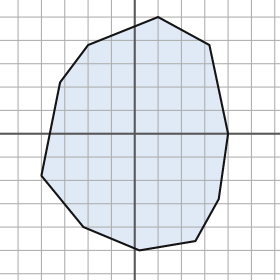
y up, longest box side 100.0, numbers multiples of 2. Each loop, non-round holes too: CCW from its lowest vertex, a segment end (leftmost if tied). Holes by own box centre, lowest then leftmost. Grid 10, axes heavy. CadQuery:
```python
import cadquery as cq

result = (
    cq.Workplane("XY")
    .moveTo(2.0, -50.0)
    .lineTo(26.0, -46.0)
    .lineTo(36.0, -28.0)
    .lineTo(40.0, 0.0)
    .lineTo(32.0, 38.0)
    .lineTo(10.0, 50.0)
    .lineTo(-20.0, 38.0)
    .lineTo(-32.0, 22.0)
    .lineTo(-40.0, -18.0)
    .lineTo(-22.0, -40.0)
    .close()
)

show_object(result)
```